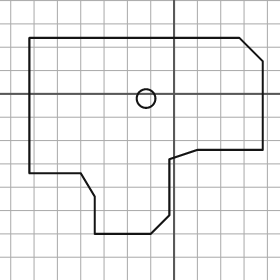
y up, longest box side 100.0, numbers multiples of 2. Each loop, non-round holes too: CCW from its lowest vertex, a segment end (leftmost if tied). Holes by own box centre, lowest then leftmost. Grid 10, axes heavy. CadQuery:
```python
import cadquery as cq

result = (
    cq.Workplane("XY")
    .moveTo(-34.0, -60.0)
    .lineTo(-10.0, -60.0)
    .lineTo(-2.0, -52.0)
    .lineTo(-2.0, -28.0)
    .lineTo(10.0, -24.0)
    .lineTo(38.0, -24.0)
    .lineTo(38.0, 14.0)
    .lineTo(28.0, 24.0)
    .lineTo(-62.0, 24.0)
    .lineTo(-62.0, -34.0)
    .lineTo(-40.0, -34.0)
    .lineTo(-34.0, -44.0)
    .close()
    .moveTo(-12.0, -2.0)
    .circle(4.0)
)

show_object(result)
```